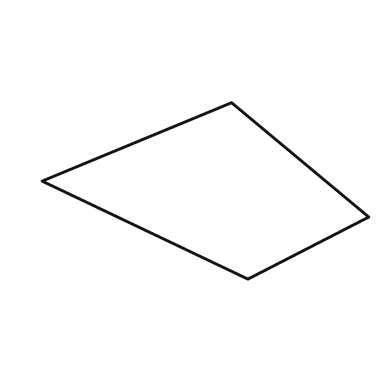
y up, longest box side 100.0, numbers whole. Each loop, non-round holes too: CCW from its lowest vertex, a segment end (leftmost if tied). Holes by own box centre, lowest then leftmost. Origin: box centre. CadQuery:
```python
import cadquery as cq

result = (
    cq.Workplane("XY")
    .moveTo(13.0, -27.0)
    .lineTo(50.0, -8.0)
    .lineTo(8.0, 27.0)
    .lineTo(-50.0, 3.0)
    .close()
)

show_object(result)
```